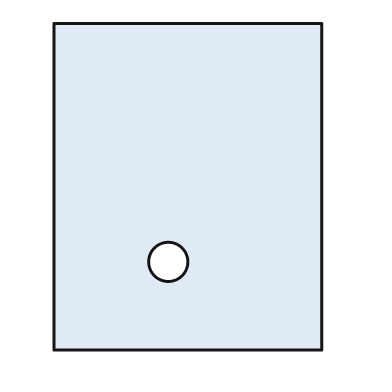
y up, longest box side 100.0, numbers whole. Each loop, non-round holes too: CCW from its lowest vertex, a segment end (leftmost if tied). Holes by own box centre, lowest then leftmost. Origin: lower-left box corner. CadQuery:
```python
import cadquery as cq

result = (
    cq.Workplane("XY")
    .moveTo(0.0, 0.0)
    .lineTo(82.0, 0.0)
    .lineTo(82.0, 100.0)
    .lineTo(0.0, 100.0)
    .close()
    .moveTo(35.0, 27.0)
    .circle(6.0)
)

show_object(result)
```